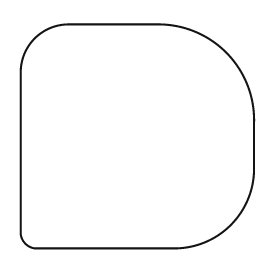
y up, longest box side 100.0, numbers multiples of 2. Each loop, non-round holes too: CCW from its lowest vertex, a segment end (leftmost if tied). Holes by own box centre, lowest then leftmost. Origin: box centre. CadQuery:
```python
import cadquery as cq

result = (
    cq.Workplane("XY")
    .moveTo(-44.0, -48.0)
    .lineTo(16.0, -48.0)
    .threePointArc((40.0, -38.0), (50.0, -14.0))
    .lineTo(50.0, 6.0)
    .threePointArc((38.0, 36.0), (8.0, 48.0))
    .lineTo(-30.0, 48.0)
    .threePointArc((-44.0, 42.0), (-50.0, 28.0))
    .lineTo(-50.0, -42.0)
    .threePointArc((-48.0, -46.0), (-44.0, -48.0))
    .close()
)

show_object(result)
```